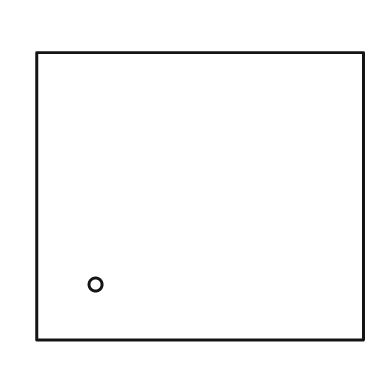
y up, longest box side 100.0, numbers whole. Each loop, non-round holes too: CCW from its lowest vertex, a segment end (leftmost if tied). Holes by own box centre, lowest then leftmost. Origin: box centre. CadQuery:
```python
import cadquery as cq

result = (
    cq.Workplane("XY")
    .moveTo(-50.0, -44.0)
    .lineTo(50.0, -44.0)
    .lineTo(50.0, 44.0)
    .lineTo(-50.0, 44.0)
    .close()
    .moveTo(-32.0, -27.0)
    .circle(2.0)
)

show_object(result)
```